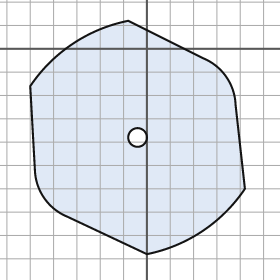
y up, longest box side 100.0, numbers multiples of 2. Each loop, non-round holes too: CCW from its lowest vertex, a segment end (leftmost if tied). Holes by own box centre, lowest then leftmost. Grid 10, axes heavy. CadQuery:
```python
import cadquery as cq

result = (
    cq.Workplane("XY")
    .moveTo(0.0, -88.0)
    .threePointArc((24.0, -78.0), (42.0, -60.0))
    .lineTo(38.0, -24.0)
    .threePointArc((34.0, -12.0), (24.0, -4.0))
    .lineTo(-8.0, 12.0)
    .threePointArc((-32.0, 2.0), (-50.0, -16.0))
    .lineTo(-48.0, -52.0)
    .threePointArc((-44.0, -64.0), (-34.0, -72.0))
    .close()
    .moveTo(-4.0, -38.0)
    .circle(4.0)
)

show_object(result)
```